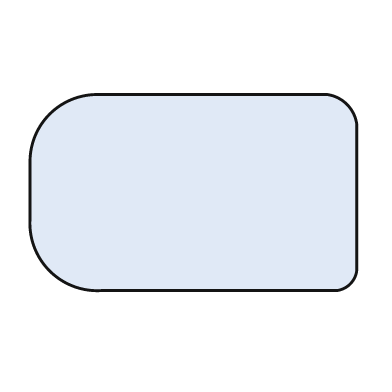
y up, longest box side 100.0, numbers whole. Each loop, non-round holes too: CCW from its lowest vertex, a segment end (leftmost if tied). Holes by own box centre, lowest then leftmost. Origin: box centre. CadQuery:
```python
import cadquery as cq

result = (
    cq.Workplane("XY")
    .moveTo(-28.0, -30.0)
    .lineTo(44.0, -30.0)
    .threePointArc((48.0, -28.0), (50.0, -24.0))
    .lineTo(50.0, 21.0)
    .threePointArc((47.0, 27.0), (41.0, 30.0))
    .lineTo(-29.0, 30.0)
    .threePointArc((-44.0, 24.0), (-50.0, 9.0))
    .lineTo(-50.0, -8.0)
    .threePointArc((-44.0, -24.0), (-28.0, -30.0))
    .close()
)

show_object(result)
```